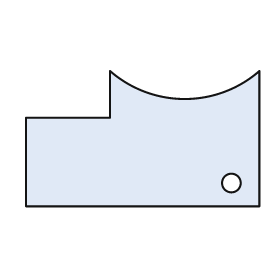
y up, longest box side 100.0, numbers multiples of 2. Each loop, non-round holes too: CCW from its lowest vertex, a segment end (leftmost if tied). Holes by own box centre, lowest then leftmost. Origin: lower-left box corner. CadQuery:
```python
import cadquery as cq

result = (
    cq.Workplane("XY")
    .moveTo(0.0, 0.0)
    .lineTo(100.0, 0.0)
    .lineTo(100.0, 58.0)
    .threePointArc((68.0, 46.0), (36.0, 58.0))
    .lineTo(36.0, 38.0)
    .lineTo(0.0, 38.0)
    .close()
    .moveTo(88.0, 10.0)
    .circle(4.0)
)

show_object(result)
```